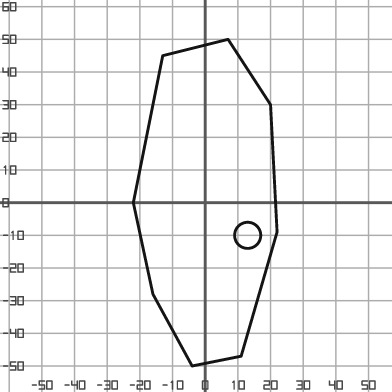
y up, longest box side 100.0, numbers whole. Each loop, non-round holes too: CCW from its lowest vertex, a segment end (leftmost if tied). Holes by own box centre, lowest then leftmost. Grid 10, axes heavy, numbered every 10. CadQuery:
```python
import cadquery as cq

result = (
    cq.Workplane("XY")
    .moveTo(-4.0, -50.0)
    .lineTo(11.0, -47.0)
    .lineTo(22.0, -9.0)
    .lineTo(20.0, 30.0)
    .lineTo(7.0, 50.0)
    .lineTo(-13.0, 45.0)
    .lineTo(-22.0, 0.0)
    .lineTo(-16.0, -28.0)
    .close()
    .moveTo(13.0, -10.0)
    .circle(4.0)
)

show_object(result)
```